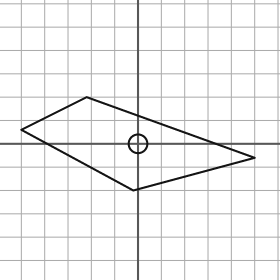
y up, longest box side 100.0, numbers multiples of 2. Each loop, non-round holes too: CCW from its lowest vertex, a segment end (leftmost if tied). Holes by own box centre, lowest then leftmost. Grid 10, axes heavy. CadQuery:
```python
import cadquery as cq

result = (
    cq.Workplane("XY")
    .moveTo(-2.0, -20.0)
    .lineTo(50.0, -6.0)
    .lineTo(-22.0, 20.0)
    .lineTo(-50.0, 6.0)
    .close()
    .moveTo(0.0, 0.0)
    .circle(4.0)
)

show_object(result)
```